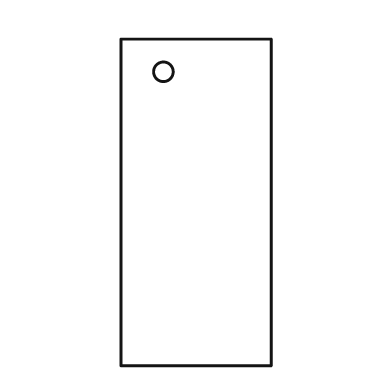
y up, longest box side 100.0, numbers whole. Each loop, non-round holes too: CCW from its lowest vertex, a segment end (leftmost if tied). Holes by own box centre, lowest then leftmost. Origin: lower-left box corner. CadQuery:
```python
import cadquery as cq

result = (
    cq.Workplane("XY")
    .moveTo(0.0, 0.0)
    .lineTo(46.0, 0.0)
    .lineTo(46.0, 100.0)
    .lineTo(0.0, 100.0)
    .close()
    .moveTo(13.0, 90.0)
    .circle(3.0)
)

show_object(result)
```